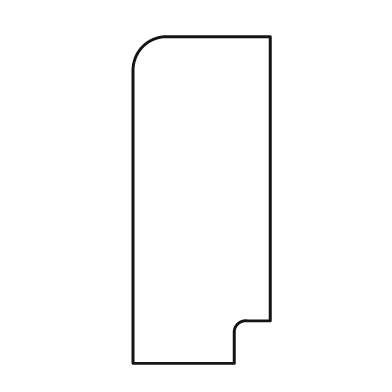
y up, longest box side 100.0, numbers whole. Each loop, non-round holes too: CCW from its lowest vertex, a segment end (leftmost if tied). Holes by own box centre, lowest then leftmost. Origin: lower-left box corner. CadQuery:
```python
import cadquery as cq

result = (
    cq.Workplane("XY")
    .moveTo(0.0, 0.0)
    .lineTo(31.0, 0.0)
    .lineTo(31.0, 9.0)
    .threePointArc((32.0, 12.0), (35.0, 13.0))
    .lineTo(42.0, 13.0)
    .lineTo(42.0, 100.0)
    .lineTo(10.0, 100.0)
    .threePointArc((3.0, 97.0), (0.0, 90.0))
    .close()
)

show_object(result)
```